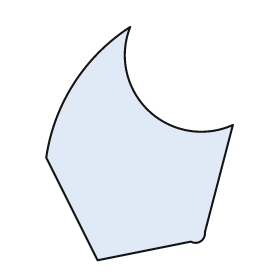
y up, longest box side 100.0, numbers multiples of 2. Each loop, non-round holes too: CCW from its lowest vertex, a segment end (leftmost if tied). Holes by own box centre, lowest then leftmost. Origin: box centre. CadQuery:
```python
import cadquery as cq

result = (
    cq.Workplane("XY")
    .moveTo(-18.0, -50.0)
    .lineTo(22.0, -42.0)
    .threePointArc((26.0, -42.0), (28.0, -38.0))
    .lineTo(40.0, 8.0)
    .threePointArc((4.0, 14.0), (-4.0, 50.0))
    .threePointArc((-28.0, 26.0), (-40.0, -6.0))
    .close()
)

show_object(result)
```